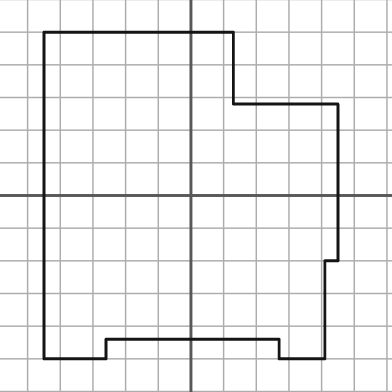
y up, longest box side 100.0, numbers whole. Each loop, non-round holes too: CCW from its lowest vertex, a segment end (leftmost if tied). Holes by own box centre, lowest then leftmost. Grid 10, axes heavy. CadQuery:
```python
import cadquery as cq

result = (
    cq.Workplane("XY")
    .moveTo(-45.0, -50.0)
    .lineTo(-26.0, -50.0)
    .lineTo(-26.0, -44.0)
    .lineTo(27.0, -44.0)
    .lineTo(27.0, -50.0)
    .lineTo(41.0, -50.0)
    .lineTo(41.0, -20.0)
    .lineTo(45.0, -20.0)
    .lineTo(45.0, 28.0)
    .lineTo(13.0, 28.0)
    .lineTo(13.0, 50.0)
    .lineTo(-45.0, 50.0)
    .close()
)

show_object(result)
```